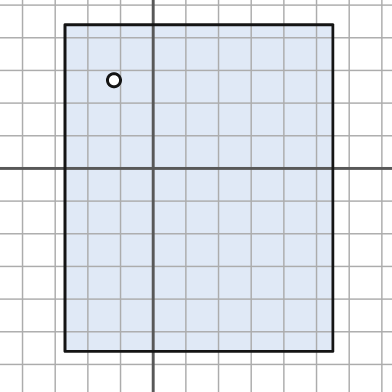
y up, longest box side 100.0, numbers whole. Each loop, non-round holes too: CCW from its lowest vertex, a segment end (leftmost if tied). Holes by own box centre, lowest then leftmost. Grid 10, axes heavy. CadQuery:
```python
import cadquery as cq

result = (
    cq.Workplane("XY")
    .moveTo(-27.0, -56.0)
    .lineTo(55.0, -56.0)
    .lineTo(55.0, 44.0)
    .lineTo(-27.0, 44.0)
    .close()
    .moveTo(-12.0, 27.0)
    .circle(2.0)
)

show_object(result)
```